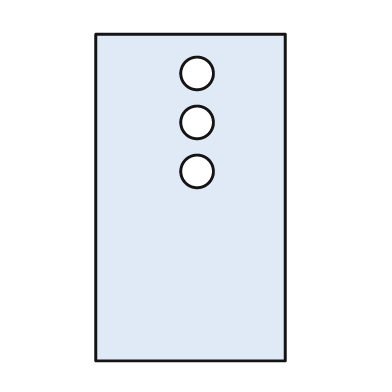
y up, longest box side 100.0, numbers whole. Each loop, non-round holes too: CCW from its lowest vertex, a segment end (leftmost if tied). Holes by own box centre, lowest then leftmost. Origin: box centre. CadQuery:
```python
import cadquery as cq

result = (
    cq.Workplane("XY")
    .moveTo(-29.0, -50.0)
    .lineTo(29.0, -50.0)
    .lineTo(29.0, 50.0)
    .lineTo(-29.0, 50.0)
    .close()
    .moveTo(2.0, 8.0)
    .circle(5.0)
    .moveTo(2.0, 23.0)
    .circle(5.0)
    .moveTo(2.0, 38.0)
    .circle(5.0)
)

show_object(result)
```